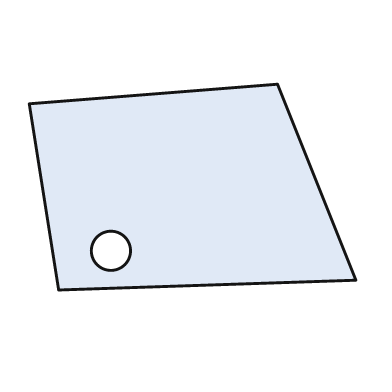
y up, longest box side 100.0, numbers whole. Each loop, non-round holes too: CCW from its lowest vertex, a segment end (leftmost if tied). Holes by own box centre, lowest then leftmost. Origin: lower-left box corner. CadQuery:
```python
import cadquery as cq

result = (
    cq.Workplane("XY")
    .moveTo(9.0, 0.0)
    .lineTo(100.0, 3.0)
    .lineTo(76.0, 63.0)
    .lineTo(0.0, 57.0)
    .close()
    .moveTo(25.0, 12.0)
    .circle(6.0)
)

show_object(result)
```